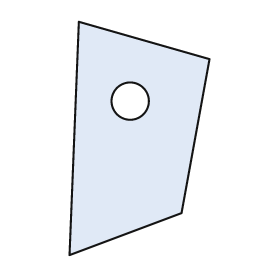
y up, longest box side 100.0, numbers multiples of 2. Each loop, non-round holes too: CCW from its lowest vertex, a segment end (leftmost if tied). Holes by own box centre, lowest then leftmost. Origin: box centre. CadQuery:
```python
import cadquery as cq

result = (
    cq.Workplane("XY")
    .moveTo(-30.0, -50.0)
    .lineTo(18.0, -32.0)
    .lineTo(30.0, 34.0)
    .lineTo(-26.0, 50.0)
    .close()
    .moveTo(-4.0, 16.0)
    .circle(8.0)
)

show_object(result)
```